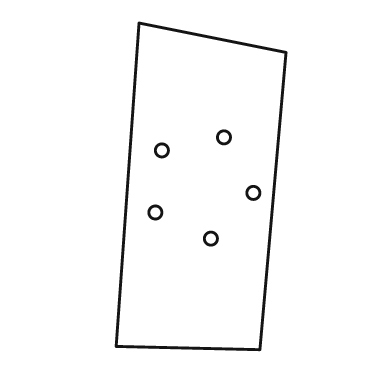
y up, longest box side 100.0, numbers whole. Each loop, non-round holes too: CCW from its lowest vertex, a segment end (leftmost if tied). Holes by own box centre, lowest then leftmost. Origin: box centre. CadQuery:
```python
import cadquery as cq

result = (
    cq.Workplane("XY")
    .moveTo(18.0, -50.0)
    .lineTo(26.0, 41.0)
    .lineTo(-19.0, 50.0)
    .lineTo(-26.0, -49.0)
    .close()
    .moveTo(3.0, -16.0)
    .circle(2.0)
    .moveTo(-14.0, -8.0)
    .circle(2.0)
    .moveTo(16.0, -2.0)
    .circle(2.0)
    .moveTo(-12.0, 11.0)
    .circle(2.0)
    .moveTo(7.0, 15.0)
    .circle(2.0)
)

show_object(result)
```